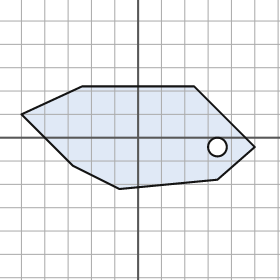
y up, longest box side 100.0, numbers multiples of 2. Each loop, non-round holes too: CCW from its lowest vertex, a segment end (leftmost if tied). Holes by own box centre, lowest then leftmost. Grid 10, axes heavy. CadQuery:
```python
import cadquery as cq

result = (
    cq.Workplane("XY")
    .moveTo(-8.0, -22.0)
    .lineTo(34.0, -18.0)
    .lineTo(50.0, -4.0)
    .lineTo(24.0, 22.0)
    .lineTo(-24.0, 22.0)
    .lineTo(-50.0, 10.0)
    .lineTo(-28.0, -12.0)
    .close()
    .moveTo(34.0, -4.0)
    .circle(4.0)
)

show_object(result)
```